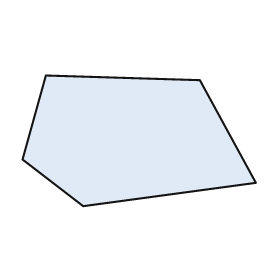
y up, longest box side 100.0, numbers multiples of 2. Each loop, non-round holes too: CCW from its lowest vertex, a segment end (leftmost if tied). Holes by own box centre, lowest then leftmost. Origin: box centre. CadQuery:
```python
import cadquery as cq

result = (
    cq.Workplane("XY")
    .moveTo(-24.0, -28.0)
    .lineTo(50.0, -18.0)
    .lineTo(26.0, 26.0)
    .lineTo(-40.0, 28.0)
    .lineTo(-50.0, -8.0)
    .close()
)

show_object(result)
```